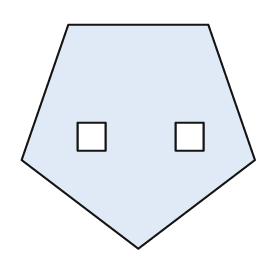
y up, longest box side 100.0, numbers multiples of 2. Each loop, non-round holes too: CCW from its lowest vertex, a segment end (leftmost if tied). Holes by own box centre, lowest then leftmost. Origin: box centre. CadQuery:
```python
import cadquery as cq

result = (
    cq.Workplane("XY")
    .moveTo(0.0, -48.0)
    .lineTo(50.0, -10.0)
    .lineTo(30.0, 48.0)
    .lineTo(-30.0, 48.0)
    .lineTo(-50.0, -10.0)
    .close()
    .moveTo(-26.0, -6.0)
    .lineTo(-14.0, -6.0)
    .lineTo(-14.0, 6.0)
    .lineTo(-26.0, 6.0)
    .close()
    .moveTo(16.0, -6.0)
    .lineTo(28.0, -6.0)
    .lineTo(28.0, 6.0)
    .lineTo(16.0, 6.0)
    .close()
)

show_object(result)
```